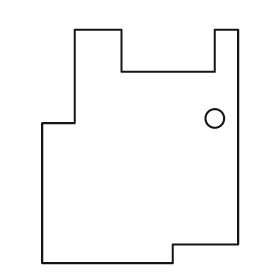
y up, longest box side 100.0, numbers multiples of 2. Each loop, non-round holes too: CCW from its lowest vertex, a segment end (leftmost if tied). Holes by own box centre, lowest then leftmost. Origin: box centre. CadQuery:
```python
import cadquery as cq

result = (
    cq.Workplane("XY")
    .moveTo(-42.0, -50.0)
    .lineTo(14.0, -50.0)
    .lineTo(14.0, -42.0)
    .lineTo(42.0, -42.0)
    .lineTo(42.0, 50.0)
    .lineTo(32.0, 50.0)
    .lineTo(32.0, 32.0)
    .lineTo(-8.0, 32.0)
    .lineTo(-8.0, 50.0)
    .lineTo(-28.0, 50.0)
    .lineTo(-28.0, 10.0)
    .lineTo(-42.0, 10.0)
    .close()
    .moveTo(32.0, 12.0)
    .circle(4.0)
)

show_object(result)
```